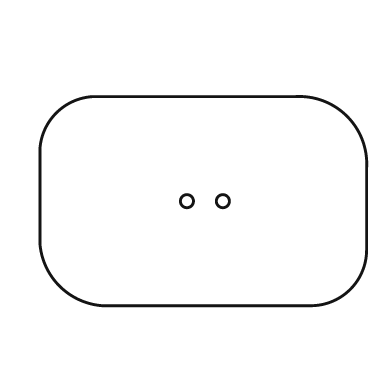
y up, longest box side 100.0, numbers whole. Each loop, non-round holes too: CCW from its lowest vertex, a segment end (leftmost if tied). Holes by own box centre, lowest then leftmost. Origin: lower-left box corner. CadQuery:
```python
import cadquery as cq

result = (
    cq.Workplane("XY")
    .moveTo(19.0, 0.0)
    .lineTo(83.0, 0.0)
    .threePointArc((95.0, 5.0), (100.0, 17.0))
    .lineTo(100.0, 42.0)
    .threePointArc((94.0, 58.0), (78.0, 64.0))
    .lineTo(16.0, 64.0)
    .threePointArc((5.0, 59.0), (0.0, 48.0))
    .lineTo(0.0, 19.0)
    .threePointArc((6.0, 6.0), (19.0, 0.0))
    .close()
    .moveTo(45.0, 32.0)
    .circle(2.0)
    .moveTo(56.0, 32.0)
    .circle(2.0)
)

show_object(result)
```